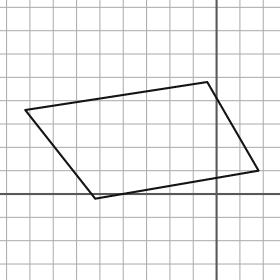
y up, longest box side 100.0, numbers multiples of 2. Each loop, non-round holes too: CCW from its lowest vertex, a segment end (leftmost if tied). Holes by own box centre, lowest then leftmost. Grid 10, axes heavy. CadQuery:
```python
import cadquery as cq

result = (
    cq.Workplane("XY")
    .moveTo(-52.0, -2.0)
    .lineTo(18.0, 10.0)
    .lineTo(-4.0, 48.0)
    .lineTo(-82.0, 36.0)
    .close()
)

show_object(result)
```